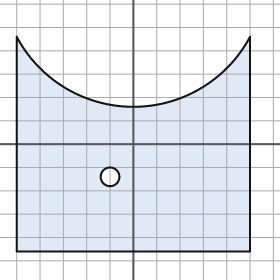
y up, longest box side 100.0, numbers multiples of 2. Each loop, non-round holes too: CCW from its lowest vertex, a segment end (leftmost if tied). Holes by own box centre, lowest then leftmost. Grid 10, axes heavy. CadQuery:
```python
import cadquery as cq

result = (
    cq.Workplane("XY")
    .moveTo(-50.0, -46.0)
    .lineTo(50.0, -46.0)
    .lineTo(50.0, 46.0)
    .threePointArc((0.0, 16.0), (-50.0, 46.0))
    .close()
    .moveTo(-10.0, -14.0)
    .circle(4.0)
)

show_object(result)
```